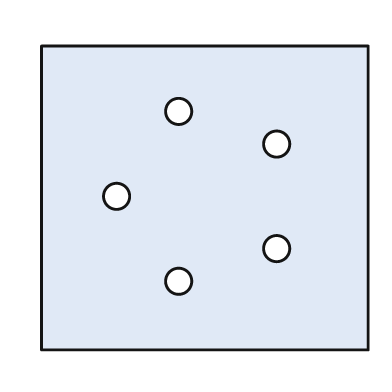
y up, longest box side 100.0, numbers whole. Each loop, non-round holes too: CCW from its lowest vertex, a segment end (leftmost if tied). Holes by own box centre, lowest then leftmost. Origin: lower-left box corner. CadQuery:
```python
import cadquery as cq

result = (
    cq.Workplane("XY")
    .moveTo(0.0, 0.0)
    .lineTo(100.0, 0.0)
    .lineTo(100.0, 93.0)
    .lineTo(0.0, 93.0)
    .close()
    .moveTo(42.0, 21.0)
    .circle(4.0)
    .moveTo(72.0, 31.0)
    .circle(4.0)
    .moveTo(23.0, 47.0)
    .circle(4.0)
    .moveTo(72.0, 63.0)
    .circle(4.0)
    .moveTo(42.0, 73.0)
    .circle(4.0)
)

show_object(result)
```